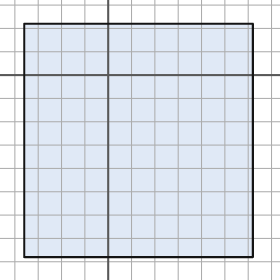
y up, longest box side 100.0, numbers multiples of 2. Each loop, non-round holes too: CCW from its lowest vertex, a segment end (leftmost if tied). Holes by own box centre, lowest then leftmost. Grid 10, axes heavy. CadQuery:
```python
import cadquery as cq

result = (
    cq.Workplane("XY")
    .moveTo(-36.0, -78.0)
    .lineTo(62.0, -78.0)
    .lineTo(62.0, 22.0)
    .lineTo(-36.0, 22.0)
    .close()
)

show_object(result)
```